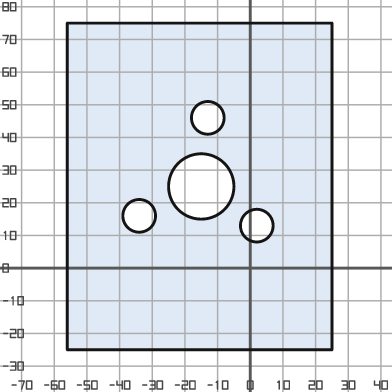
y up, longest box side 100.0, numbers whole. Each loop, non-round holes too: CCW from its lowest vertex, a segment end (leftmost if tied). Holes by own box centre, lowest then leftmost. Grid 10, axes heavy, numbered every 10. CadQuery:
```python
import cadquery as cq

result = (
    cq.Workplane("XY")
    .moveTo(-56.0, -25.0)
    .lineTo(25.0, -25.0)
    .lineTo(25.0, 75.0)
    .lineTo(-56.0, 75.0)
    .close()
    .moveTo(2.0, 13.0)
    .circle(5.0)
    .moveTo(-34.0, 16.0)
    .circle(5.0)
    .moveTo(-15.0, 25.0)
    .circle(10.0)
    .moveTo(-13.0, 46.0)
    .circle(5.0)
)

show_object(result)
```